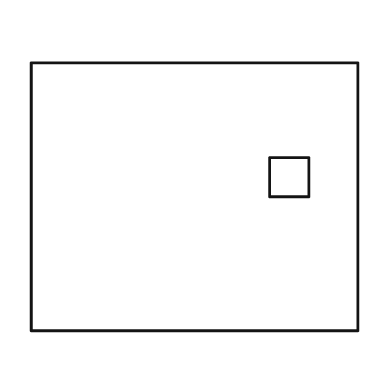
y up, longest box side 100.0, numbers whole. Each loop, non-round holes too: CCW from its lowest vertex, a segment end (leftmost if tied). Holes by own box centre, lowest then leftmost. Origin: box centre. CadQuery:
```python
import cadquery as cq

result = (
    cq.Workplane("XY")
    .moveTo(-50.0, -41.0)
    .lineTo(50.0, -41.0)
    .lineTo(50.0, 41.0)
    .lineTo(-50.0, 41.0)
    .close()
    .moveTo(23.0, 0.0)
    .lineTo(35.0, 0.0)
    .lineTo(35.0, 12.0)
    .lineTo(23.0, 12.0)
    .close()
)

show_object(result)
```